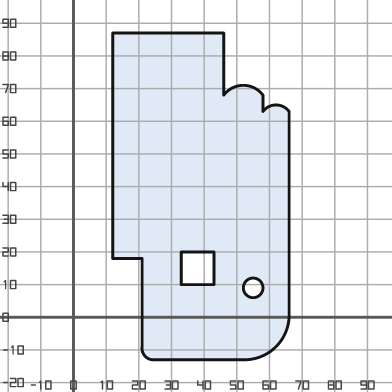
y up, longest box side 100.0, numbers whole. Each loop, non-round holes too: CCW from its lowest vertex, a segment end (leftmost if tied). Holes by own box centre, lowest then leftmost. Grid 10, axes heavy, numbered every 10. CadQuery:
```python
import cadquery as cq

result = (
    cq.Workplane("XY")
    .moveTo(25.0, -13.0)
    .lineTo(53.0, -13.0)
    .threePointArc((62.0, -9.0), (66.0, 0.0))
    .lineTo(66.0, 63.0)
    .threePointArc((62.0, 65.0), (58.0, 63.0))
    .lineTo(58.0, 68.0)
    .threePointArc((52.0, 71.0), (46.0, 68.0))
    .lineTo(46.0, 87.0)
    .lineTo(12.0, 87.0)
    .lineTo(12.0, 18.0)
    .lineTo(21.0, 18.0)
    .lineTo(21.0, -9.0)
    .threePointArc((22.0, -12.0), (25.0, -13.0))
    .close()
    .moveTo(55.0, 9.0)
    .circle(3.0)
    .moveTo(33.0, 10.0)
    .lineTo(43.0, 10.0)
    .lineTo(43.0, 20.0)
    .lineTo(33.0, 20.0)
    .close()
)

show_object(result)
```